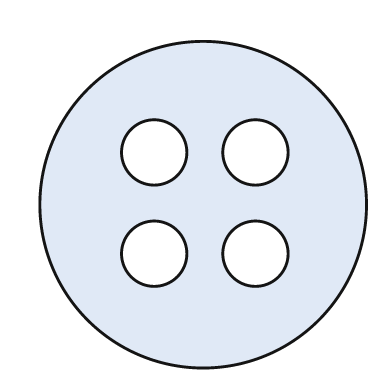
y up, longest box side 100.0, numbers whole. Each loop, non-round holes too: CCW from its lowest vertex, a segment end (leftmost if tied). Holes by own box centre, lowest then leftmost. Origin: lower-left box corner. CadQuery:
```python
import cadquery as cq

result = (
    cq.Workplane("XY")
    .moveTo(50.0, 50.0)
    .circle(50.0)
    .moveTo(35.0, 35.0)
    .circle(10.0)
    .moveTo(66.0, 35.0)
    .circle(10.0)
    .moveTo(35.0, 66.0)
    .circle(10.0)
    .moveTo(66.0, 66.0)
    .circle(10.0)
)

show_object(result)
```